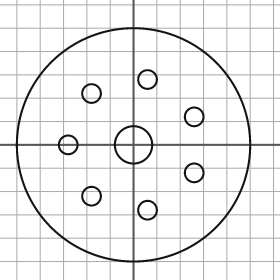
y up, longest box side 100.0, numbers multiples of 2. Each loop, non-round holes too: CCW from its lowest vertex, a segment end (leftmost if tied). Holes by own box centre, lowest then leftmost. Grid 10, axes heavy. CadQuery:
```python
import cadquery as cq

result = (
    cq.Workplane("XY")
    .moveTo(0.0, 0.0)
    .circle(50.0)
    .moveTo(6.0, -28.0)
    .circle(4.0)
    .moveTo(-18.0, -22.0)
    .circle(4.0)
    .moveTo(26.0, -12.0)
    .circle(4.0)
    .moveTo(-28.0, 0.0)
    .circle(4.0)
    .moveTo(0.0, 0.0)
    .circle(8.0)
    .moveTo(26.0, 12.0)
    .circle(4.0)
    .moveTo(-18.0, 22.0)
    .circle(4.0)
    .moveTo(6.0, 28.0)
    .circle(4.0)
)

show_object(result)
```